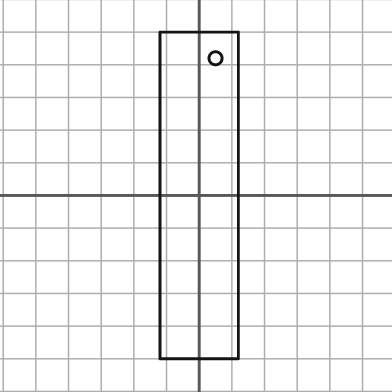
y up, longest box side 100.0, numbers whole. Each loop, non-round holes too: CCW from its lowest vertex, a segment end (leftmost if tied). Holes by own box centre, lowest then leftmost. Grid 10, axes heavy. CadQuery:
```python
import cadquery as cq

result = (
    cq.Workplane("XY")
    .moveTo(-12.0, -50.0)
    .lineTo(12.0, -50.0)
    .lineTo(12.0, 50.0)
    .lineTo(-12.0, 50.0)
    .close()
    .moveTo(5.0, 42.0)
    .circle(2.0)
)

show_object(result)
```